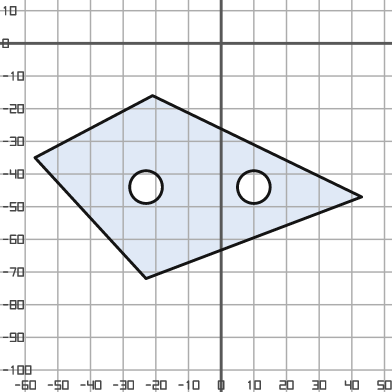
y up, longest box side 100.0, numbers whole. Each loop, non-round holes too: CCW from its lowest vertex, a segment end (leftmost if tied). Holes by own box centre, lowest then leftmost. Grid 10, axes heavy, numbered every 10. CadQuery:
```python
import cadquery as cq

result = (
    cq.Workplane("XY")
    .moveTo(-23.0, -72.0)
    .lineTo(43.0, -47.0)
    .lineTo(-21.0, -16.0)
    .lineTo(-57.0, -35.0)
    .close()
    .moveTo(-23.0, -44.0)
    .circle(5.0)
    .moveTo(10.0, -44.0)
    .circle(5.0)
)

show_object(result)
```